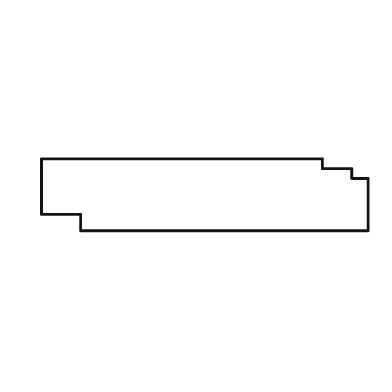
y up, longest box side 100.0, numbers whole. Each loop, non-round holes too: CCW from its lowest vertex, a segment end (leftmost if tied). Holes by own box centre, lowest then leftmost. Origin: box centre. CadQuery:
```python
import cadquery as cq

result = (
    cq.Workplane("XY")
    .moveTo(-38.0, -11.0)
    .lineTo(50.0, -11.0)
    .lineTo(50.0, 5.0)
    .lineTo(45.0, 5.0)
    .lineTo(45.0, 8.0)
    .lineTo(36.0, 8.0)
    .lineTo(36.0, 11.0)
    .lineTo(-50.0, 11.0)
    .lineTo(-50.0, -6.0)
    .lineTo(-38.0, -6.0)
    .close()
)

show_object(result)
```